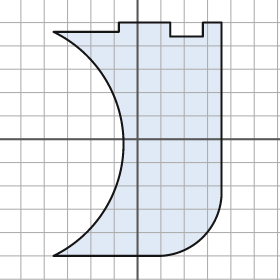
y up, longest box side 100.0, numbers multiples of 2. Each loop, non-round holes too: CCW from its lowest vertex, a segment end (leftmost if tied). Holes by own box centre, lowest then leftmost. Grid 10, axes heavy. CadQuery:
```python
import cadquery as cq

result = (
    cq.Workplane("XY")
    .moveTo(-36.0, -50.0)
    .lineTo(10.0, -50.0)
    .threePointArc((28.0, -42.0), (36.0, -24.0))
    .lineTo(36.0, 50.0)
    .lineTo(28.0, 50.0)
    .lineTo(28.0, 44.0)
    .lineTo(14.0, 44.0)
    .lineTo(14.0, 50.0)
    .lineTo(-8.0, 50.0)
    .lineTo(-8.0, 46.0)
    .lineTo(-36.0, 46.0)
    .threePointArc((-6.0, -2.0), (-36.0, -50.0))
    .close()
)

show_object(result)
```